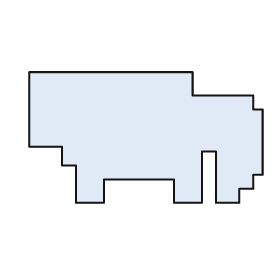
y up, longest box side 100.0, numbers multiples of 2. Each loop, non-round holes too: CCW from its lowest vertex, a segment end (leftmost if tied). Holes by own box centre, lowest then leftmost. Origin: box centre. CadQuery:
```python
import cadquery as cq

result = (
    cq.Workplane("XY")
    .moveTo(-30.0, -28.0)
    .lineTo(-18.0, -28.0)
    .lineTo(-18.0, -18.0)
    .lineTo(12.0, -18.0)
    .lineTo(12.0, -28.0)
    .lineTo(24.0, -28.0)
    .lineTo(24.0, -6.0)
    .lineTo(30.0, -6.0)
    .lineTo(30.0, -28.0)
    .lineTo(40.0, -28.0)
    .lineTo(40.0, -22.0)
    .lineTo(46.0, -22.0)
    .lineTo(46.0, -16.0)
    .lineTo(50.0, -16.0)
    .lineTo(50.0, 12.0)
    .lineTo(46.0, 12.0)
    .lineTo(46.0, 18.0)
    .lineTo(20.0, 18.0)
    .lineTo(20.0, 28.0)
    .lineTo(-50.0, 28.0)
    .lineTo(-50.0, -4.0)
    .lineTo(-36.0, -4.0)
    .lineTo(-36.0, -12.0)
    .lineTo(-30.0, -12.0)
    .close()
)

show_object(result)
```